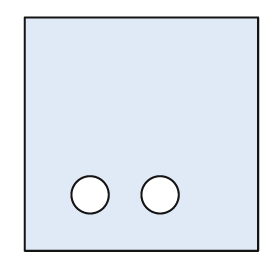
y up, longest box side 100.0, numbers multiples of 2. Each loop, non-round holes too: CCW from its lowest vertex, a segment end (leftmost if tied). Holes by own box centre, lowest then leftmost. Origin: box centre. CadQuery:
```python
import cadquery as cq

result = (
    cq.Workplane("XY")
    .moveTo(-50.0, -50.0)
    .lineTo(50.0, -50.0)
    .lineTo(50.0, 50.0)
    .lineTo(-50.0, 50.0)
    .close()
    .moveTo(-22.0, -26.0)
    .circle(8.0)
    .moveTo(8.0, -26.0)
    .circle(8.0)
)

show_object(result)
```